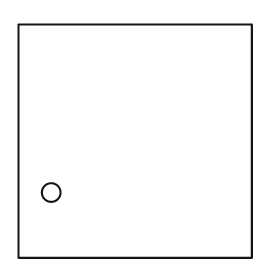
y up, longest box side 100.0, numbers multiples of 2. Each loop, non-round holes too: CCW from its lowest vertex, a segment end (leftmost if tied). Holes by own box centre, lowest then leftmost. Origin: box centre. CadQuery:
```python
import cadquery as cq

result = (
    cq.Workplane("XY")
    .moveTo(-50.0, -50.0)
    .lineTo(50.0, -50.0)
    .lineTo(50.0, 50.0)
    .lineTo(-50.0, 50.0)
    .close()
    .moveTo(-36.0, -22.0)
    .circle(4.0)
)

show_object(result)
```